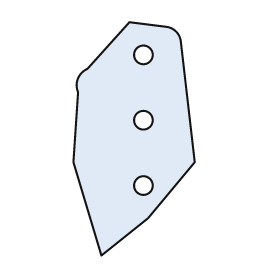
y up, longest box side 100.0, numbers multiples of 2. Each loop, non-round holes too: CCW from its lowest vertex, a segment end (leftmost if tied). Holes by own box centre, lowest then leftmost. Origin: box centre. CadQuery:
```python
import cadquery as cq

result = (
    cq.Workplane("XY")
    .moveTo(-14.0, -50.0)
    .lineTo(6.0, -34.0)
    .lineTo(26.0, -10.0)
    .lineTo(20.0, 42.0)
    .threePointArc((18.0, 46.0), (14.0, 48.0))
    .lineTo(-2.0, 50.0)
    .lineTo(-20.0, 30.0)
    .threePointArc((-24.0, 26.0), (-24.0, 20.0))
    .lineTo(-26.0, -10.0)
    .close()
    .moveTo(4.0, -20.0)
    .circle(4.0)
    .moveTo(4.0, 8.0)
    .circle(4.0)
    .moveTo(4.0, 36.0)
    .circle(4.0)
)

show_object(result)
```